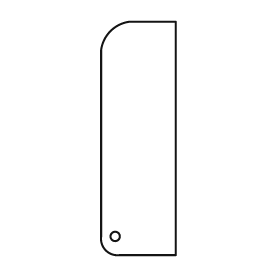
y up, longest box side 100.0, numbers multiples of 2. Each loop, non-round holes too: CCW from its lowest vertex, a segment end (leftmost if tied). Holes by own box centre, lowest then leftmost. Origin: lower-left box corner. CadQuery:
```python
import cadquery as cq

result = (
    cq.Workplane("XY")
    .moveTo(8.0, 0.0)
    .lineTo(32.0, 0.0)
    .lineTo(32.0, 100.0)
    .lineTo(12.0, 100.0)
    .threePointArc((4.0, 96.0), (0.0, 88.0))
    .lineTo(0.0, 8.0)
    .threePointArc((2.0, 2.0), (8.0, 0.0))
    .close()
    .moveTo(6.0, 8.0)
    .circle(2.0)
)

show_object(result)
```